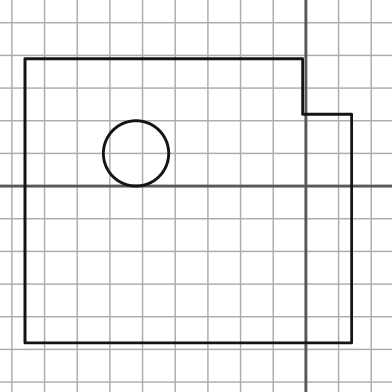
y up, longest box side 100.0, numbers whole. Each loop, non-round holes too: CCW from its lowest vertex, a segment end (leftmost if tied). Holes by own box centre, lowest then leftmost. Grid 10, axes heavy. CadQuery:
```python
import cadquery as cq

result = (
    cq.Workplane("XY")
    .moveTo(-86.0, -48.0)
    .lineTo(14.0, -48.0)
    .lineTo(14.0, 22.0)
    .lineTo(-1.0, 22.0)
    .lineTo(-1.0, 39.0)
    .lineTo(-86.0, 39.0)
    .close()
    .moveTo(-52.0, 10.0)
    .circle(10.0)
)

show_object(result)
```